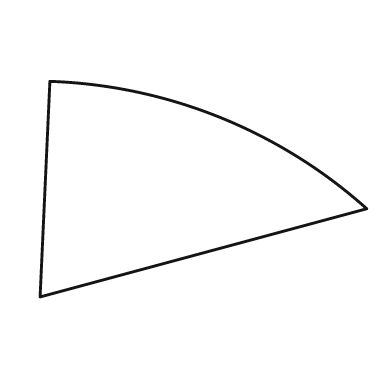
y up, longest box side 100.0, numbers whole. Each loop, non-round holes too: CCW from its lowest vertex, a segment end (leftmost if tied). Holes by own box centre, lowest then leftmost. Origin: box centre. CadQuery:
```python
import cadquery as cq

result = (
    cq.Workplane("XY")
    .moveTo(-50.0, -33.0)
    .lineTo(50.0, -6.0)
    .threePointArc((5.0, 22.0), (-47.0, 33.0))
    .close()
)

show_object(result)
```